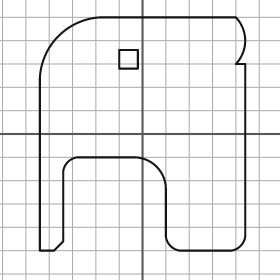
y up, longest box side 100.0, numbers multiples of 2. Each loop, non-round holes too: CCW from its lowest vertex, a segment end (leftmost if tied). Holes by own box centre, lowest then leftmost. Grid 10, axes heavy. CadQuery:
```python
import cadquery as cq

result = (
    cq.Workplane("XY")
    .moveTo(-44.0, -50.0)
    .lineTo(-38.0, -50.0)
    .lineTo(-34.0, -46.0)
    .lineTo(-34.0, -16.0)
    .threePointArc((-32.0, -12.0), (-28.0, -10.0))
    .lineTo(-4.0, -10.0)
    .threePointArc((6.0, -14.0), (10.0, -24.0))
    .lineTo(10.0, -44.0)
    .threePointArc((12.0, -48.0), (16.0, -50.0))
    .lineTo(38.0, -50.0)
    .threePointArc((42.0, -48.0), (44.0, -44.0))
    .lineTo(44.0, 30.0)
    .lineTo(40.0, 30.0)
    .threePointArc((44.0, 40.0), (40.0, 50.0))
    .lineTo(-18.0, 50.0)
    .threePointArc((-36.0, 42.0), (-44.0, 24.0))
    .close()
    .moveTo(-10.0, 28.0)
    .lineTo(-2.0, 28.0)
    .lineTo(-2.0, 36.0)
    .lineTo(-10.0, 36.0)
    .close()
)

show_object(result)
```